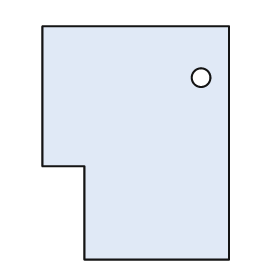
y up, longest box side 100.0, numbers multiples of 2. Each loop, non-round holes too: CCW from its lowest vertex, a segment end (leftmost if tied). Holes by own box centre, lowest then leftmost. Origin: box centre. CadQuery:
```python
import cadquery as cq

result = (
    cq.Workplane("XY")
    .moveTo(-22.0, -50.0)
    .lineTo(40.0, -50.0)
    .lineTo(40.0, 50.0)
    .lineTo(-40.0, 50.0)
    .lineTo(-40.0, -10.0)
    .lineTo(-22.0, -10.0)
    .close()
    .moveTo(28.0, 28.0)
    .circle(4.0)
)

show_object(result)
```